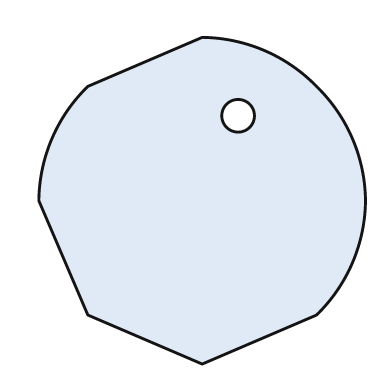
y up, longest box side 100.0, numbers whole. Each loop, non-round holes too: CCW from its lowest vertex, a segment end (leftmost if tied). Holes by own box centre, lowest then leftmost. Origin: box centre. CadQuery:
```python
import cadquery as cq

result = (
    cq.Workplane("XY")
    .moveTo(0.0, -50.0)
    .lineTo(35.0, -35.0)
    .threePointArc((46.0, -19.0), (50.0, 0.0))
    .threePointArc((46.0, 19.0), (35.0, 35.0))
    .threePointArc((19.0, 46.0), (0.0, 50.0))
    .lineTo(-35.0, 35.0)
    .threePointArc((-46.0, 19.0), (-50.0, 0.0))
    .lineTo(-35.0, -35.0)
    .close()
    .moveTo(11.0, 26.0)
    .circle(5.0)
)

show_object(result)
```